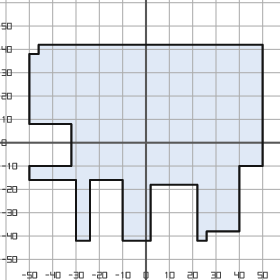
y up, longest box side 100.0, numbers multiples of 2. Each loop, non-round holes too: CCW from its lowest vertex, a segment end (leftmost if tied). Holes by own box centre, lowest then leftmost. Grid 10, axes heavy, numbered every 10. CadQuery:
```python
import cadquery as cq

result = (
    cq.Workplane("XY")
    .moveTo(-30.0, -42.0)
    .lineTo(-24.0, -42.0)
    .lineTo(-24.0, -16.0)
    .lineTo(-10.0, -16.0)
    .lineTo(-10.0, -42.0)
    .lineTo(2.0, -42.0)
    .lineTo(2.0, -18.0)
    .lineTo(22.0, -18.0)
    .lineTo(22.0, -42.0)
    .lineTo(26.0, -42.0)
    .lineTo(26.0, -38.0)
    .lineTo(40.0, -38.0)
    .lineTo(40.0, -10.0)
    .lineTo(50.0, -10.0)
    .lineTo(50.0, 42.0)
    .lineTo(-46.0, 42.0)
    .lineTo(-46.0, 38.0)
    .lineTo(-50.0, 38.0)
    .lineTo(-50.0, 8.0)
    .lineTo(-32.0, 8.0)
    .lineTo(-32.0, -10.0)
    .lineTo(-50.0, -10.0)
    .lineTo(-50.0, -16.0)
    .lineTo(-30.0, -16.0)
    .close()
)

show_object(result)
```